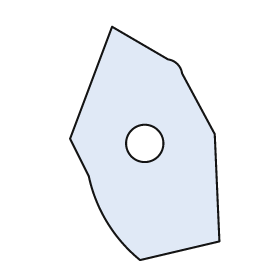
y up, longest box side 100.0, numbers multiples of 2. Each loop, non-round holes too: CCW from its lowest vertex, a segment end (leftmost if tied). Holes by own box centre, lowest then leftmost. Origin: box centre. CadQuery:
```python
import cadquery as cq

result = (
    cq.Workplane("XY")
    .moveTo(-2.0, -50.0)
    .lineTo(32.0, -42.0)
    .lineTo(30.0, 4.0)
    .lineTo(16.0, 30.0)
    .threePointArc((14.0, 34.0), (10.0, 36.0))
    .lineTo(-14.0, 50.0)
    .lineTo(-32.0, 2.0)
    .lineTo(-24.0, -14.0)
    .threePointArc((-16.0, -34.0), (-2.0, -50.0))
    .close()
    .moveTo(0.0, 0.0)
    .circle(8.0)
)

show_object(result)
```